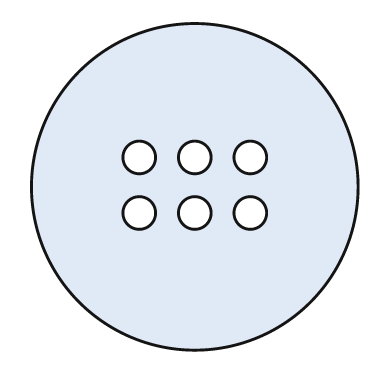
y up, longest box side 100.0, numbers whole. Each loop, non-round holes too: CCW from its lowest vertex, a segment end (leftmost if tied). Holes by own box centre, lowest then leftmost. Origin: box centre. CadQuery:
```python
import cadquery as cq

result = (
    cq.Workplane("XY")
    .moveTo(0.0, 0.0)
    .circle(50.0)
    .moveTo(-17.0, -8.0)
    .circle(5.0)
    .moveTo(0.0, -8.0)
    .circle(5.0)
    .moveTo(17.0, -8.0)
    .circle(5.0)
    .moveTo(-17.0, 9.0)
    .circle(5.0)
    .moveTo(0.0, 9.0)
    .circle(5.0)
    .moveTo(17.0, 9.0)
    .circle(5.0)
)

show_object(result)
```